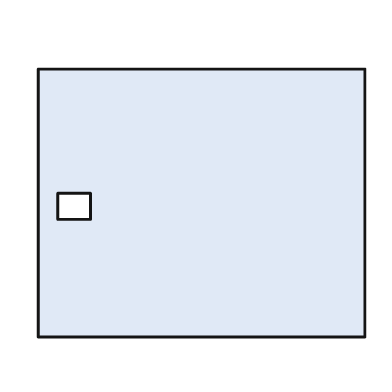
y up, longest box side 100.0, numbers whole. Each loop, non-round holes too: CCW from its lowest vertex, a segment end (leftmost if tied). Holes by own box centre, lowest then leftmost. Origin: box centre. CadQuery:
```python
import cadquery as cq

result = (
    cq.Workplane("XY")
    .moveTo(-50.0, -41.0)
    .lineTo(50.0, -41.0)
    .lineTo(50.0, 41.0)
    .lineTo(-50.0, 41.0)
    .close()
    .moveTo(-44.0, -5.0)
    .lineTo(-34.0, -5.0)
    .lineTo(-34.0, 3.0)
    .lineTo(-44.0, 3.0)
    .close()
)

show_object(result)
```